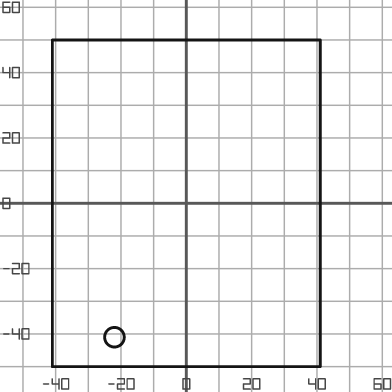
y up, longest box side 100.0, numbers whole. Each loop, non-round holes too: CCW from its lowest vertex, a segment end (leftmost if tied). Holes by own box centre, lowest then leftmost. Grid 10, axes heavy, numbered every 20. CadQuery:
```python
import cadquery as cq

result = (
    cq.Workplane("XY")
    .moveTo(-41.0, -50.0)
    .lineTo(41.0, -50.0)
    .lineTo(41.0, 50.0)
    .lineTo(-41.0, 50.0)
    .close()
    .moveTo(-22.0, -41.0)
    .circle(3.0)
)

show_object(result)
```